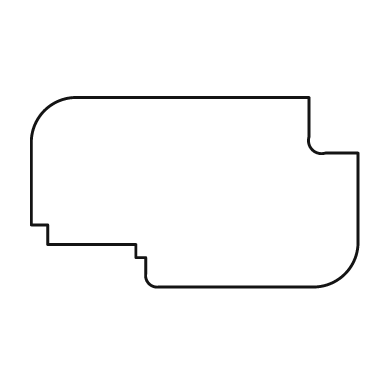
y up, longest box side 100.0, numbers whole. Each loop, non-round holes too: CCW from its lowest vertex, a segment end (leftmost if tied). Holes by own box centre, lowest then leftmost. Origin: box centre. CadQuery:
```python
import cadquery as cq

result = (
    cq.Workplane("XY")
    .moveTo(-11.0, -29.0)
    .lineTo(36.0, -29.0)
    .threePointArc((46.0, -25.0), (50.0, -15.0))
    .lineTo(50.0, 12.0)
    .lineTo(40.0, 12.0)
    .threePointArc((36.0, 13.0), (35.0, 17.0))
    .lineTo(35.0, 29.0)
    .lineTo(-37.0, 29.0)
    .threePointArc((-46.0, 25.0), (-50.0, 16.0))
    .lineTo(-50.0, -10.0)
    .lineTo(-45.0, -10.0)
    .lineTo(-45.0, -16.0)
    .lineTo(-18.0, -16.0)
    .lineTo(-18.0, -20.0)
    .lineTo(-15.0, -20.0)
    .lineTo(-15.0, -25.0)
    .threePointArc((-14.0, -28.0), (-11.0, -29.0))
    .close()
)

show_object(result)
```